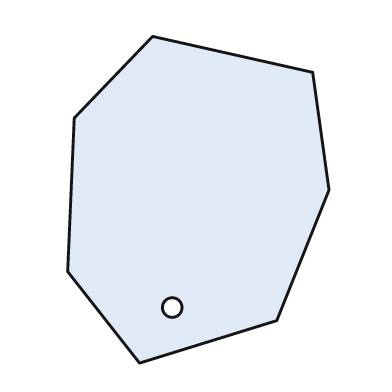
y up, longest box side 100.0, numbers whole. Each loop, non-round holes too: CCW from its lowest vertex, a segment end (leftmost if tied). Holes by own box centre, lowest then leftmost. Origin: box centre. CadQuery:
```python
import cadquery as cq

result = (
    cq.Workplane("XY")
    .moveTo(-18.0, -50.0)
    .lineTo(24.0, -37.0)
    .lineTo(40.0, 3.0)
    .lineTo(35.0, 39.0)
    .lineTo(-14.0, 50.0)
    .lineTo(-38.0, 25.0)
    .lineTo(-40.0, -22.0)
    .close()
    .moveTo(-8.0, -33.0)
    .circle(3.0)
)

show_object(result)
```